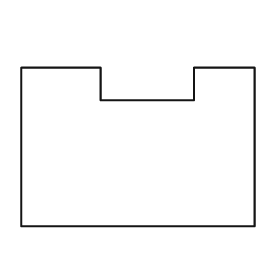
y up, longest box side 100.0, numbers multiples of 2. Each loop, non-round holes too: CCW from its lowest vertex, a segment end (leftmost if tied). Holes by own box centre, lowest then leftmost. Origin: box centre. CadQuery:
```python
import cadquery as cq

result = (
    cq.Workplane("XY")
    .moveTo(-50.0, -34.0)
    .lineTo(50.0, -34.0)
    .lineTo(50.0, 34.0)
    .lineTo(24.0, 34.0)
    .lineTo(24.0, 20.0)
    .lineTo(-16.0, 20.0)
    .lineTo(-16.0, 34.0)
    .lineTo(-50.0, 34.0)
    .close()
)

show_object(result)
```